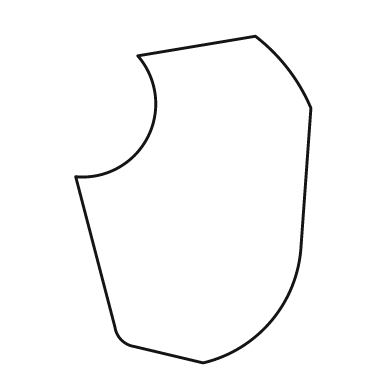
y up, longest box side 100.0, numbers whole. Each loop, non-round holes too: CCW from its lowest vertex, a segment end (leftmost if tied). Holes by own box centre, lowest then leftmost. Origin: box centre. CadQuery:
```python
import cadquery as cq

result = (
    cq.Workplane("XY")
    .moveTo(3.0, -50.0)
    .threePointArc((24.0, -37.0), (33.0, -14.0))
    .lineTo(36.0, 28.0)
    .threePointArc((29.0, 40.0), (19.0, 50.0))
    .lineTo(-17.0, 44.0)
    .threePointArc((-14.0, 19.0), (-36.0, 7.0))
    .lineTo(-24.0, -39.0)
    .threePointArc((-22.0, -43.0), (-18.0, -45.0))
    .close()
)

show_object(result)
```